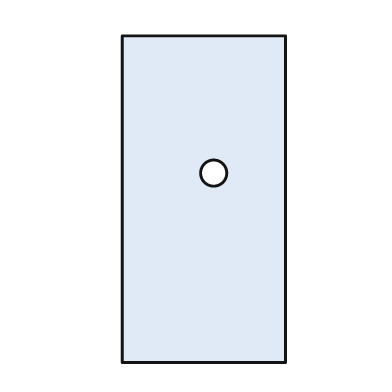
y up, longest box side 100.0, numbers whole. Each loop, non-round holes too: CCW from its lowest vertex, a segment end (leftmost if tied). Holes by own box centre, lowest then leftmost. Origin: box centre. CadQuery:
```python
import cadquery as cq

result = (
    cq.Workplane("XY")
    .moveTo(-25.0, -50.0)
    .lineTo(25.0, -50.0)
    .lineTo(25.0, 50.0)
    .lineTo(-25.0, 50.0)
    .close()
    .moveTo(3.0, 8.0)
    .circle(4.0)
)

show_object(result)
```